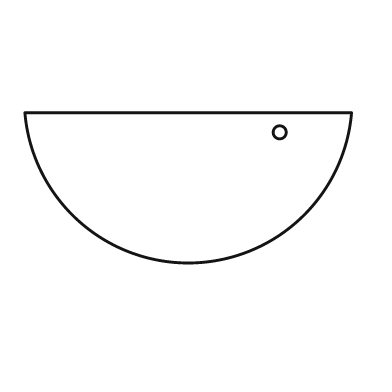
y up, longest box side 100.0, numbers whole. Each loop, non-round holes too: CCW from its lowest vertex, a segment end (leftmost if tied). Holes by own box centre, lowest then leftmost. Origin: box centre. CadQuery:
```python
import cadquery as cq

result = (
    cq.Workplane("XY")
    .moveTo(-50.0, 23.0)
    .threePointArc((0.0, -23.0), (50.0, 23.0))
    .close()
    .moveTo(28.0, 17.0)
    .circle(2.0)
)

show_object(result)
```